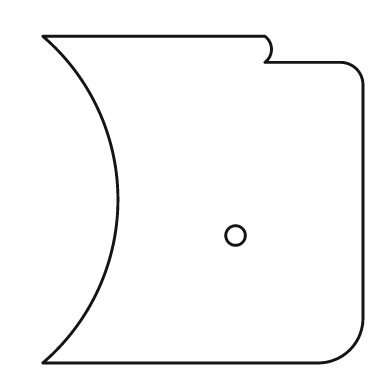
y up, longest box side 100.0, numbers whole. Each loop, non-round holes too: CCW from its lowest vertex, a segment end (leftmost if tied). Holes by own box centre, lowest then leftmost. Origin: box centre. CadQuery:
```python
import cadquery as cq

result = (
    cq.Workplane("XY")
    .moveTo(-49.0, -50.0)
    .lineTo(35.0, -50.0)
    .threePointArc((45.0, -46.0), (49.0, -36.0))
    .lineTo(49.0, 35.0)
    .threePointArc((47.0, 40.0), (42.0, 42.0))
    .lineTo(19.0, 42.0)
    .threePointArc((21.0, 46.0), (19.0, 50.0))
    .lineTo(-49.0, 50.0)
    .threePointArc((-26.0, 0.0), (-49.0, -50.0))
    .close()
    .moveTo(10.0, -11.0)
    .circle(3.0)
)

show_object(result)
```